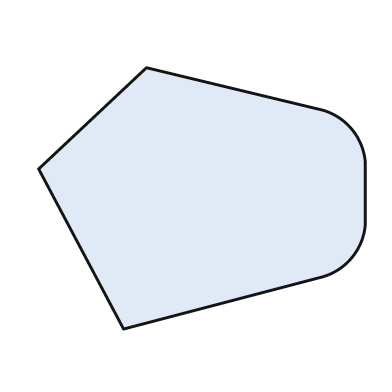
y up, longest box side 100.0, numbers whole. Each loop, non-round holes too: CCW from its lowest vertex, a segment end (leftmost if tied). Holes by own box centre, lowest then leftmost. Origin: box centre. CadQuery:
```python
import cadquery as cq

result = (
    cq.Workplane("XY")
    .moveTo(-24.0, -40.0)
    .lineTo(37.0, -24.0)
    .threePointArc((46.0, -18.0), (50.0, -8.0))
    .lineTo(50.0, 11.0)
    .threePointArc((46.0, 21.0), (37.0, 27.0))
    .lineTo(-17.0, 40.0)
    .lineTo(-50.0, 9.0)
    .close()
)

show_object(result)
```